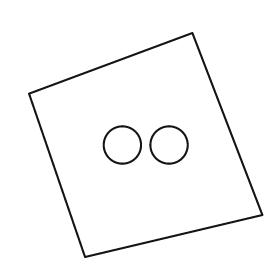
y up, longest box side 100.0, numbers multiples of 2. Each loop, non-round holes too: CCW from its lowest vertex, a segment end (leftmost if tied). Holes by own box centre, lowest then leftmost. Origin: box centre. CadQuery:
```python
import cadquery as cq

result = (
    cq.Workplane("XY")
    .moveTo(-26.0, -48.0)
    .lineTo(50.0, -30.0)
    .lineTo(20.0, 48.0)
    .lineTo(-50.0, 22.0)
    .close()
    .moveTo(-10.0, 0.0)
    .circle(8.0)
    .moveTo(10.0, 0.0)
    .circle(8.0)
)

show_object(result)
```